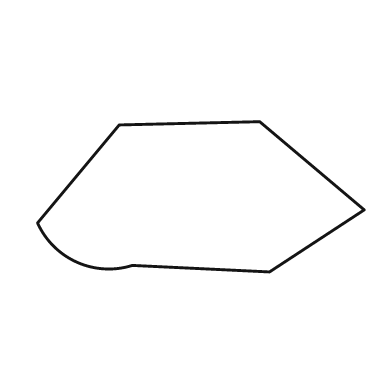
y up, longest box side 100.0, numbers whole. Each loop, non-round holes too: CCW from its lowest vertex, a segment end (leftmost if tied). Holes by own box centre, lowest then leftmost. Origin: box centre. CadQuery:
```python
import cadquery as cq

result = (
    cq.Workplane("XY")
    .moveTo(21.0, -23.0)
    .lineTo(50.0, -4.0)
    .lineTo(18.0, 23.0)
    .lineTo(-25.0, 22.0)
    .lineTo(-50.0, -8.0)
    .threePointArc((-38.0, -20.0), (-21.0, -21.0))
    .close()
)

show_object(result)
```